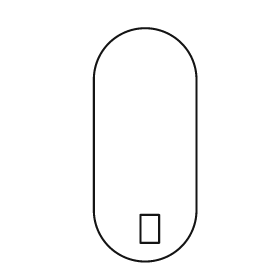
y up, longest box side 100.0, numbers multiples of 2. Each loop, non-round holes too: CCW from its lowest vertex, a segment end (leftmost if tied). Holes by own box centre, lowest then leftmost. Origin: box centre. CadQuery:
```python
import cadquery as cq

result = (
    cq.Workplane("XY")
    .moveTo(-22.0, -28.0)
    .threePointArc((0.0, -50.0), (22.0, -28.0))
    .lineTo(22.0, 28.0)
    .threePointArc((0.0, 50.0), (-22.0, 28.0))
    .close()
    .moveTo(-2.0, -42.0)
    .lineTo(6.0, -42.0)
    .lineTo(6.0, -30.0)
    .lineTo(-2.0, -30.0)
    .close()
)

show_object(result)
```